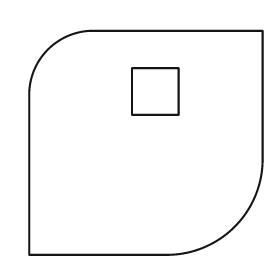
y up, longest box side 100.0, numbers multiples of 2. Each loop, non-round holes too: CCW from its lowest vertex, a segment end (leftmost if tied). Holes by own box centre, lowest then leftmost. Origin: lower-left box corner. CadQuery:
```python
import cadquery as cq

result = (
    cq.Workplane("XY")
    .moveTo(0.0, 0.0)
    .lineTo(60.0, 0.0)
    .threePointArc((88.0, 12.0), (100.0, 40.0))
    .lineTo(100.0, 96.0)
    .lineTo(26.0, 96.0)
    .threePointArc((8.0, 88.0), (0.0, 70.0))
    .close()
    .moveTo(44.0, 60.0)
    .lineTo(64.0, 60.0)
    .lineTo(64.0, 80.0)
    .lineTo(44.0, 80.0)
    .close()
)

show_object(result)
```